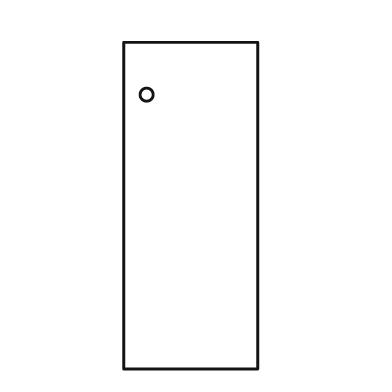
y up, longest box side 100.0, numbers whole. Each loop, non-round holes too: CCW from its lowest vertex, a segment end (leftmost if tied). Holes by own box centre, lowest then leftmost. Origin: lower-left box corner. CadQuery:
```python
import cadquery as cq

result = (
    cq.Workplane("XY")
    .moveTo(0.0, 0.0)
    .lineTo(41.0, 0.0)
    .lineTo(41.0, 100.0)
    .lineTo(0.0, 100.0)
    .close()
    .moveTo(7.0, 84.0)
    .circle(2.0)
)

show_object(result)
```